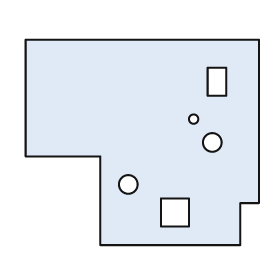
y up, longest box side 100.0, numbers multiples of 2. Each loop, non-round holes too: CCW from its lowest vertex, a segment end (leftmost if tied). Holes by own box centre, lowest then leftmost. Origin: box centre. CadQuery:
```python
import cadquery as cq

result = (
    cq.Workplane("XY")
    .moveTo(-18.0, -44.0)
    .lineTo(42.0, -44.0)
    .lineTo(42.0, -26.0)
    .lineTo(50.0, -26.0)
    .lineTo(50.0, 44.0)
    .lineTo(-50.0, 44.0)
    .lineTo(-50.0, -6.0)
    .lineTo(-18.0, -6.0)
    .close()
    .moveTo(8.0, -36.0)
    .lineTo(20.0, -36.0)
    .lineTo(20.0, -24.0)
    .lineTo(8.0, -24.0)
    .close()
    .moveTo(-6.0, -18.0)
    .circle(4.0)
    .moveTo(30.0, 0.0)
    .circle(4.0)
    .moveTo(22.0, 10.0)
    .circle(2.0)
    .moveTo(28.0, 20.0)
    .lineTo(36.0, 20.0)
    .lineTo(36.0, 32.0)
    .lineTo(28.0, 32.0)
    .close()
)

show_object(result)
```